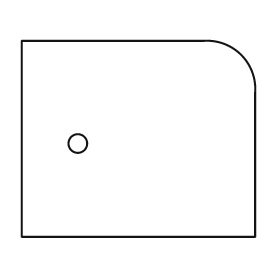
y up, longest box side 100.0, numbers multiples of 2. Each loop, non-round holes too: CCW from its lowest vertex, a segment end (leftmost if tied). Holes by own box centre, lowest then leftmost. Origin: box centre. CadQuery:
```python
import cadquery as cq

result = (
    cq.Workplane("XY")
    .moveTo(-50.0, -42.0)
    .lineTo(50.0, -42.0)
    .lineTo(50.0, 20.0)
    .threePointArc((44.0, 36.0), (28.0, 42.0))
    .lineTo(-50.0, 42.0)
    .close()
    .moveTo(-26.0, -2.0)
    .circle(4.0)
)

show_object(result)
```